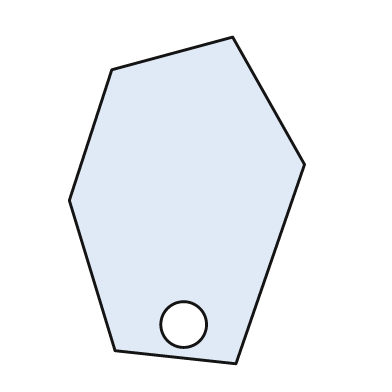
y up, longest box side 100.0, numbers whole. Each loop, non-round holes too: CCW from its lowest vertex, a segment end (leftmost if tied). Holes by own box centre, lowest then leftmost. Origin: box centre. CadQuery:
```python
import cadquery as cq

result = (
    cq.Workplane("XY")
    .moveTo(15.0, -50.0)
    .lineTo(36.0, 11.0)
    .lineTo(14.0, 50.0)
    .lineTo(-23.0, 40.0)
    .lineTo(-36.0, 0.0)
    .lineTo(-22.0, -46.0)
    .close()
    .moveTo(-1.0, -38.0)
    .circle(7.0)
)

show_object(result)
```